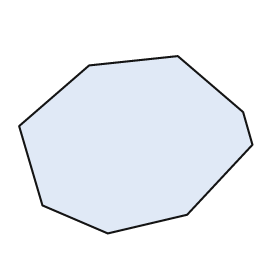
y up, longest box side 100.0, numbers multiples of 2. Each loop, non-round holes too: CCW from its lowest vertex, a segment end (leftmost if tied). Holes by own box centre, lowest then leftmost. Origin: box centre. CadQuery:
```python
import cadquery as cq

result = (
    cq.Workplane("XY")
    .moveTo(-12.0, -38.0)
    .lineTo(22.0, -30.0)
    .lineTo(50.0, 0.0)
    .lineTo(46.0, 14.0)
    .lineTo(18.0, 38.0)
    .lineTo(-20.0, 34.0)
    .lineTo(-50.0, 8.0)
    .lineTo(-40.0, -26.0)
    .close()
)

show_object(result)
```